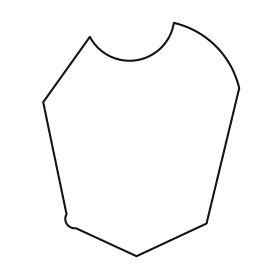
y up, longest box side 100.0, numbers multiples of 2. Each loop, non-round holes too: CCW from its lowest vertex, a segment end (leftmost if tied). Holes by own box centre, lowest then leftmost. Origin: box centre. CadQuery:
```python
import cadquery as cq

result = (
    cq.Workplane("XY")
    .moveTo(-2.0, -50.0)
    .lineTo(28.0, -36.0)
    .lineTo(42.0, 22.0)
    .threePointArc((32.0, 40.0), (14.0, 50.0))
    .threePointArc((-2.0, 34.0), (-22.0, 44.0))
    .lineTo(-42.0, 16.0)
    .lineTo(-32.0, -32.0)
    .threePointArc((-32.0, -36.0), (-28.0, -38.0))
    .close()
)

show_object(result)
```